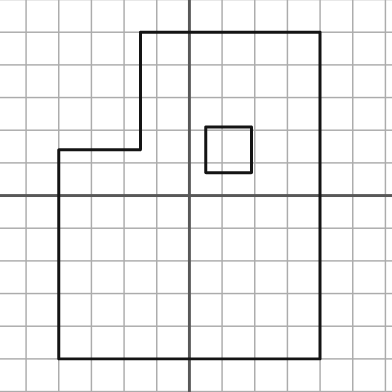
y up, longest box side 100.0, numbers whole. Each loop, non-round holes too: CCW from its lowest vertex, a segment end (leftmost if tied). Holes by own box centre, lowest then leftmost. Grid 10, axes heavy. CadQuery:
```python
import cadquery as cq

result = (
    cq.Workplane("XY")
    .moveTo(-40.0, -50.0)
    .lineTo(40.0, -50.0)
    .lineTo(40.0, 50.0)
    .lineTo(-15.0, 50.0)
    .lineTo(-15.0, 14.0)
    .lineTo(-40.0, 14.0)
    .close()
    .moveTo(5.0, 7.0)
    .lineTo(19.0, 7.0)
    .lineTo(19.0, 21.0)
    .lineTo(5.0, 21.0)
    .close()
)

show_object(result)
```